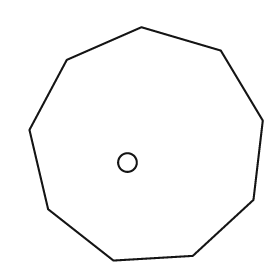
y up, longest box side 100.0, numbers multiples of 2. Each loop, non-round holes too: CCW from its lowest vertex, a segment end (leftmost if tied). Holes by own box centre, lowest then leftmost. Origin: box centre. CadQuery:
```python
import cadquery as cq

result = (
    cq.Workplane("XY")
    .moveTo(-14.0, -50.0)
    .lineTo(20.0, -48.0)
    .lineTo(46.0, -24.0)
    .lineTo(50.0, 10.0)
    .lineTo(32.0, 40.0)
    .lineTo(-2.0, 50.0)
    .lineTo(-34.0, 36.0)
    .lineTo(-50.0, 6.0)
    .lineTo(-42.0, -28.0)
    .close()
    .moveTo(-8.0, -8.0)
    .circle(4.0)
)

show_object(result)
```